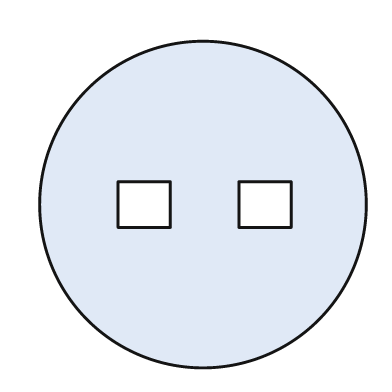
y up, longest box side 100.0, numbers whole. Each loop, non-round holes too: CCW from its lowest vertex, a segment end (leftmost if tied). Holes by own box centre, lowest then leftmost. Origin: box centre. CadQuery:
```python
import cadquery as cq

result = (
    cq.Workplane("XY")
    .moveTo(0.0, 0.0)
    .circle(50.0)
    .moveTo(-26.0, -7.0)
    .lineTo(-10.0, -7.0)
    .lineTo(-10.0, 7.0)
    .lineTo(-26.0, 7.0)
    .close()
    .moveTo(11.0, -7.0)
    .lineTo(27.0, -7.0)
    .lineTo(27.0, 7.0)
    .lineTo(11.0, 7.0)
    .close()
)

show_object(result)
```